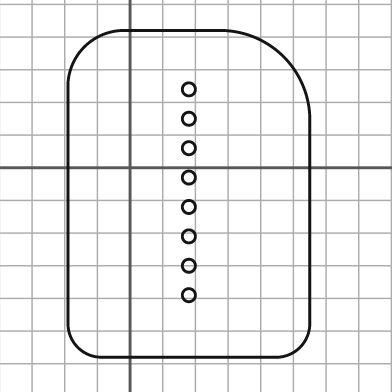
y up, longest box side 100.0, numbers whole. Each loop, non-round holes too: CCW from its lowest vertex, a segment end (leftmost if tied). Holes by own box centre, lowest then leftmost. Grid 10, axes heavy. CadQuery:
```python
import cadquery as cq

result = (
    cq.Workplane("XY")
    .moveTo(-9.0, -58.0)
    .lineTo(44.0, -58.0)
    .threePointArc((52.0, -55.0), (55.0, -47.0))
    .lineTo(55.0, 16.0)
    .threePointArc((47.0, 34.0), (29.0, 42.0))
    .lineTo(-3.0, 42.0)
    .threePointArc((-14.0, 37.0), (-19.0, 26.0))
    .lineTo(-19.0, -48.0)
    .threePointArc((-16.0, -55.0), (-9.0, -58.0))
    .close()
    .moveTo(18.0, -39.0)
    .circle(2.0)
    .moveTo(18.0, -30.0)
    .circle(2.0)
    .moveTo(18.0, -21.0)
    .circle(2.0)
    .moveTo(18.0, -12.0)
    .circle(2.0)
    .moveTo(18.0, -3.0)
    .circle(2.0)
    .moveTo(18.0, 6.0)
    .circle(2.0)
    .moveTo(18.0, 15.0)
    .circle(2.0)
    .moveTo(18.0, 24.0)
    .circle(2.0)
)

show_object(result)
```